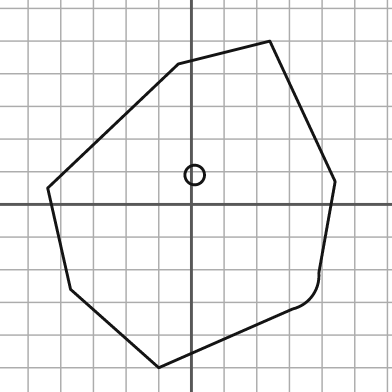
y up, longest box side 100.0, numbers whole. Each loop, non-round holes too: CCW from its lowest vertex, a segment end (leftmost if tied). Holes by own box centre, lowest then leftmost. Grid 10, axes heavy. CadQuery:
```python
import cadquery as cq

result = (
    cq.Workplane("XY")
    .moveTo(-10.0, -50.0)
    .lineTo(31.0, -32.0)
    .threePointArc((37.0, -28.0), (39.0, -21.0))
    .lineTo(44.0, 7.0)
    .lineTo(24.0, 50.0)
    .lineTo(-4.0, 43.0)
    .lineTo(-44.0, 5.0)
    .lineTo(-37.0, -26.0)
    .close()
    .moveTo(1.0, 9.0)
    .circle(3.0)
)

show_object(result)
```